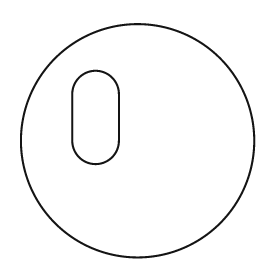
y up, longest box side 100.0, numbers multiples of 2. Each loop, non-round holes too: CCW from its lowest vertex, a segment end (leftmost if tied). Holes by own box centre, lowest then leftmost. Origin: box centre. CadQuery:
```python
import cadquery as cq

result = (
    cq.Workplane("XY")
    .moveTo(0.0, 0.0)
    .circle(50.0)
    .moveTo(-28.0, 0.0)
    .threePointArc((-18.0, -10.0), (-8.0, 0.0))
    .lineTo(-8.0, 20.0)
    .threePointArc((-18.0, 30.0), (-28.0, 20.0))
    .close()
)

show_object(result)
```